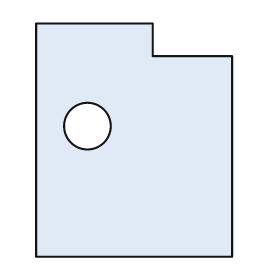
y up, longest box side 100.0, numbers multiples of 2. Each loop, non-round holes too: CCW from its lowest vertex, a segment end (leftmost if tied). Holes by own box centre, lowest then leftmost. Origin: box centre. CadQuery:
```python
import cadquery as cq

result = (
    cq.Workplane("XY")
    .moveTo(-42.0, -50.0)
    .lineTo(42.0, -50.0)
    .lineTo(42.0, 36.0)
    .lineTo(8.0, 36.0)
    .lineTo(8.0, 50.0)
    .lineTo(-42.0, 50.0)
    .close()
    .moveTo(-20.0, 6.0)
    .circle(10.0)
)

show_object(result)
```